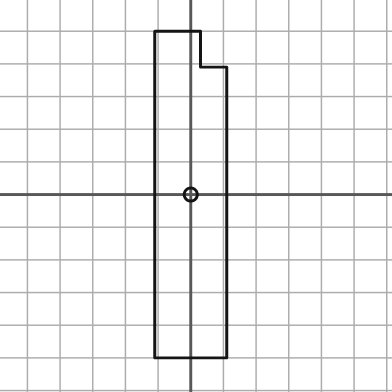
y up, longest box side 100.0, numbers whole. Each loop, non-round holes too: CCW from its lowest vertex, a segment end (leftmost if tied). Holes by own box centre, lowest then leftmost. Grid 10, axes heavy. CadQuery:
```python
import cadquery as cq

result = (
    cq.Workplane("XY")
    .moveTo(-11.0, -50.0)
    .lineTo(11.0, -50.0)
    .lineTo(11.0, 39.0)
    .lineTo(3.0, 39.0)
    .lineTo(3.0, 50.0)
    .lineTo(-11.0, 50.0)
    .close()
    .moveTo(0.0, 0.0)
    .circle(2.0)
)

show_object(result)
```